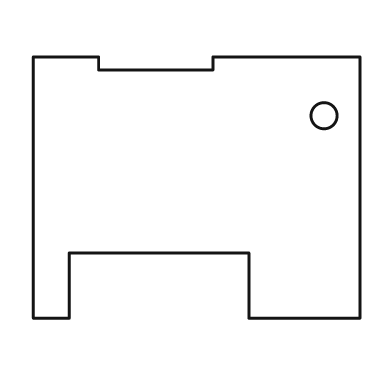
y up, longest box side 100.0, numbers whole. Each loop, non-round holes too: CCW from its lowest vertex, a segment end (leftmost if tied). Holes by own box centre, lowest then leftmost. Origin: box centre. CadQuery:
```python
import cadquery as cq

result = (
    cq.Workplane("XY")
    .moveTo(-50.0, -40.0)
    .lineTo(-39.0, -40.0)
    .lineTo(-39.0, -20.0)
    .lineTo(16.0, -20.0)
    .lineTo(16.0, -40.0)
    .lineTo(50.0, -40.0)
    .lineTo(50.0, 40.0)
    .lineTo(5.0, 40.0)
    .lineTo(5.0, 36.0)
    .lineTo(-30.0, 36.0)
    .lineTo(-30.0, 40.0)
    .lineTo(-50.0, 40.0)
    .close()
    .moveTo(39.0, 22.0)
    .circle(4.0)
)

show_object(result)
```